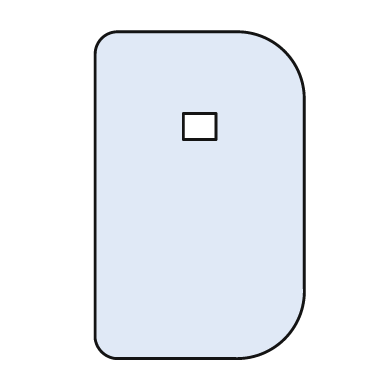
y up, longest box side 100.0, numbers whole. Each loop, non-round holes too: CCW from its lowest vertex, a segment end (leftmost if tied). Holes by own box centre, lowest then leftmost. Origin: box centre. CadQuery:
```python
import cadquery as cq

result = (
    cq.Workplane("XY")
    .moveTo(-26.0, -50.0)
    .lineTo(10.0, -50.0)
    .threePointArc((26.0, -44.0), (32.0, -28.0))
    .lineTo(32.0, 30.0)
    .threePointArc((26.0, 44.0), (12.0, 50.0))
    .lineTo(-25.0, 50.0)
    .threePointArc((-30.0, 48.0), (-32.0, 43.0))
    .lineTo(-32.0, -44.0)
    .threePointArc((-30.0, -48.0), (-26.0, -50.0))
    .close()
    .moveTo(-5.0, 17.0)
    .lineTo(5.0, 17.0)
    .lineTo(5.0, 25.0)
    .lineTo(-5.0, 25.0)
    .close()
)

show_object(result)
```